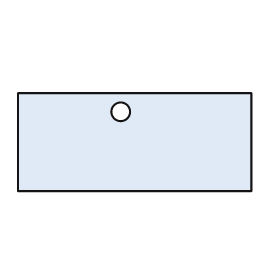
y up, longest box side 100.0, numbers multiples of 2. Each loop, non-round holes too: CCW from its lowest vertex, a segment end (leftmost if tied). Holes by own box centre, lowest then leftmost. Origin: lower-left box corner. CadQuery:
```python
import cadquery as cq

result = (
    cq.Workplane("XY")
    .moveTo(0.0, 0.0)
    .lineTo(100.0, 0.0)
    .lineTo(100.0, 42.0)
    .lineTo(0.0, 42.0)
    .close()
    .moveTo(44.0, 34.0)
    .circle(4.0)
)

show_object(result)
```